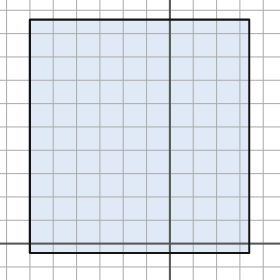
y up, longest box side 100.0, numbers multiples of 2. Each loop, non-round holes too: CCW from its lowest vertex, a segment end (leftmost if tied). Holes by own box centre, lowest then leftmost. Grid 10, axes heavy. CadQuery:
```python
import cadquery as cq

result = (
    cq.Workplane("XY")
    .moveTo(-60.0, -4.0)
    .lineTo(34.0, -4.0)
    .lineTo(34.0, 96.0)
    .lineTo(-60.0, 96.0)
    .close()
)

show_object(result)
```